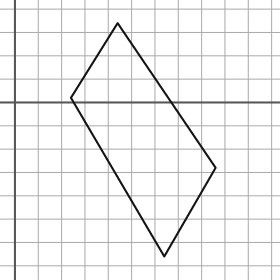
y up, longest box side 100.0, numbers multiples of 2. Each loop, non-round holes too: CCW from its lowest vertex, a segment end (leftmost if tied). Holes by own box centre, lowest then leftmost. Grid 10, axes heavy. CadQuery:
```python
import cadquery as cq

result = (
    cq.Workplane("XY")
    .moveTo(64.0, -66.0)
    .lineTo(86.0, -28.0)
    .lineTo(44.0, 34.0)
    .lineTo(24.0, 2.0)
    .close()
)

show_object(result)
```